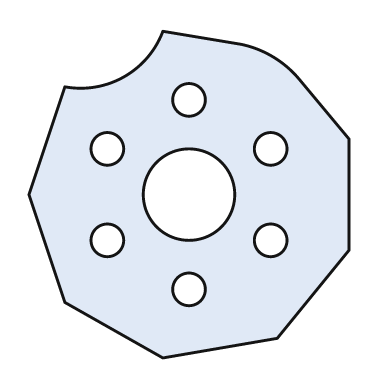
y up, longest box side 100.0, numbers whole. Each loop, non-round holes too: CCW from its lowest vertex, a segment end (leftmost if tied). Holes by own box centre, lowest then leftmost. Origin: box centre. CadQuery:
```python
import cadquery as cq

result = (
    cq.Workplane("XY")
    .moveTo(-8.0, -50.0)
    .lineTo(27.0, -44.0)
    .lineTo(49.0, -17.0)
    .lineTo(49.0, 17.0)
    .lineTo(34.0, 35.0)
    .threePointArc((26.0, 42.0), (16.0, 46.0))
    .lineTo(-8.0, 50.0)
    .threePointArc((-20.0, 36.0), (-38.0, 33.0))
    .lineTo(-49.0, 0.0)
    .lineTo(-38.0, -33.0)
    .close()
    .moveTo(0.0, -29.0)
    .circle(5.0)
    .moveTo(-25.0, -14.0)
    .circle(5.0)
    .moveTo(25.0, -14.0)
    .circle(5.0)
    .moveTo(0.0, 0.0)
    .circle(14.0)
    .moveTo(-25.0, 14.0)
    .circle(5.0)
    .moveTo(25.0, 14.0)
    .circle(5.0)
    .moveTo(0.0, 29.0)
    .circle(5.0)
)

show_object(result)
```